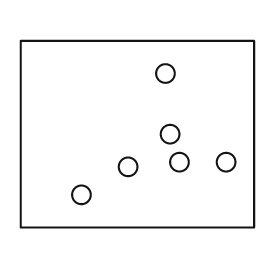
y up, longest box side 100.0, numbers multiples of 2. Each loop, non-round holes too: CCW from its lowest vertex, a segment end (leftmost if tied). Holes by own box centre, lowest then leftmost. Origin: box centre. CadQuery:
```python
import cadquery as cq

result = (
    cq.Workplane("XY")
    .moveTo(-50.0, -40.0)
    .lineTo(50.0, -40.0)
    .lineTo(50.0, 40.0)
    .lineTo(-50.0, 40.0)
    .close()
    .moveTo(-24.0, -26.0)
    .circle(4.0)
    .moveTo(-4.0, -14.0)
    .circle(4.0)
    .moveTo(18.0, -12.0)
    .circle(4.0)
    .moveTo(38.0, -12.0)
    .circle(4.0)
    .moveTo(14.0, 0.0)
    .circle(4.0)
    .moveTo(12.0, 26.0)
    .circle(4.0)
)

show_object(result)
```